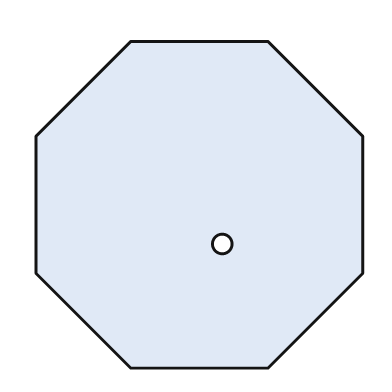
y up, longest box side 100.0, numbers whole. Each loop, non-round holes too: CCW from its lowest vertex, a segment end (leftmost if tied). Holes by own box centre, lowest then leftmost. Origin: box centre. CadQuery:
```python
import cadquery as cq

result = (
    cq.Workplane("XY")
    .moveTo(-21.0, -50.0)
    .lineTo(21.0, -50.0)
    .lineTo(50.0, -21.0)
    .lineTo(50.0, 21.0)
    .lineTo(21.0, 50.0)
    .lineTo(-21.0, 50.0)
    .lineTo(-50.0, 21.0)
    .lineTo(-50.0, -21.0)
    .close()
    .moveTo(7.0, -12.0)
    .circle(3.0)
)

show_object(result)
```